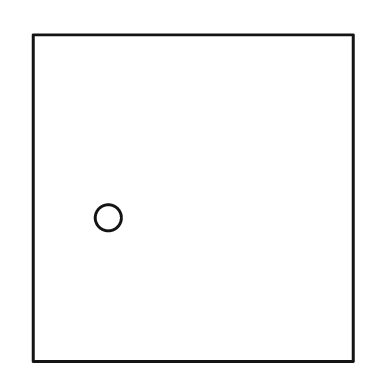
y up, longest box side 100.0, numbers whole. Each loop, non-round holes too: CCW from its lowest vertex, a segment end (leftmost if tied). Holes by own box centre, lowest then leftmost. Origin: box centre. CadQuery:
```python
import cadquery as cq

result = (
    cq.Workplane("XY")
    .moveTo(-49.0, -50.0)
    .lineTo(49.0, -50.0)
    .lineTo(49.0, 50.0)
    .lineTo(-49.0, 50.0)
    .close()
    .moveTo(-26.0, -6.0)
    .circle(4.0)
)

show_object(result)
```